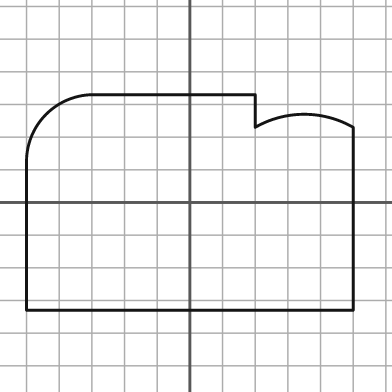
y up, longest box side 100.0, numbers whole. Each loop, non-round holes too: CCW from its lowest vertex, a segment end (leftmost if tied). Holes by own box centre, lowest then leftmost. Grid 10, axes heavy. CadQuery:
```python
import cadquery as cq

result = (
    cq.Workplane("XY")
    .moveTo(-50.0, -33.0)
    .lineTo(50.0, -33.0)
    .lineTo(50.0, 23.0)
    .threePointArc((35.0, 27.0), (20.0, 23.0))
    .lineTo(20.0, 33.0)
    .lineTo(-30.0, 33.0)
    .threePointArc((-44.0, 27.0), (-50.0, 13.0))
    .close()
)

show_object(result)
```